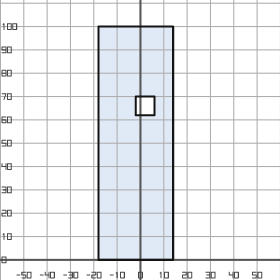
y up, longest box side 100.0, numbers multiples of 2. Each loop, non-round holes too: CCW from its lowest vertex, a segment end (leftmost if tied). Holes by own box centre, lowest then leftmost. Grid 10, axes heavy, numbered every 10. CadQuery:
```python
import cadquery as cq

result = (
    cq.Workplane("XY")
    .moveTo(-18.0, 0.0)
    .lineTo(14.0, 0.0)
    .lineTo(14.0, 100.0)
    .lineTo(-18.0, 100.0)
    .close()
    .moveTo(-2.0, 62.0)
    .lineTo(6.0, 62.0)
    .lineTo(6.0, 70.0)
    .lineTo(-2.0, 70.0)
    .close()
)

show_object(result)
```